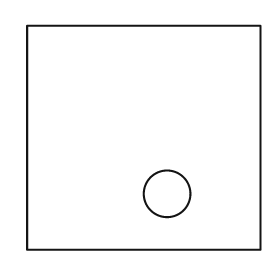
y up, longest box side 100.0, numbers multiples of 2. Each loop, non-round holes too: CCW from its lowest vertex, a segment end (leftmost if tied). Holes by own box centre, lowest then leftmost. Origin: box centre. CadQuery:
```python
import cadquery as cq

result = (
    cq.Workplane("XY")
    .moveTo(-50.0, -48.0)
    .lineTo(50.0, -48.0)
    .lineTo(50.0, 48.0)
    .lineTo(-50.0, 48.0)
    .close()
    .moveTo(10.0, -24.0)
    .circle(10.0)
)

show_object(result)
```